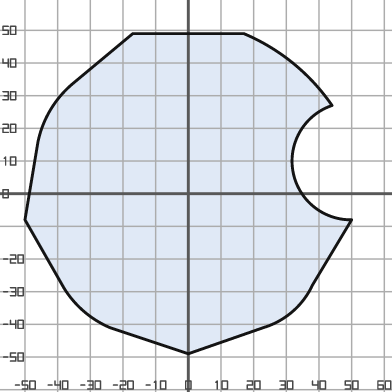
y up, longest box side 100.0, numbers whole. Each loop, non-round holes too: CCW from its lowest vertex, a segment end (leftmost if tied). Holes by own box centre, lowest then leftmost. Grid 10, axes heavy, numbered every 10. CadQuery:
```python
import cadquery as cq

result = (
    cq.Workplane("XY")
    .moveTo(0.0, -49.0)
    .lineTo(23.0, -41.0)
    .threePointArc((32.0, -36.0), (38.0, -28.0))
    .lineTo(50.0, -8.0)
    .threePointArc((32.0, 7.0), (44.0, 27.0))
    .threePointArc((32.0, 40.0), (17.0, 49.0))
    .lineTo(-17.0, 49.0)
    .lineTo(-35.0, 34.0)
    .threePointArc((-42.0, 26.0), (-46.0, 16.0))
    .lineTo(-50.0, -8.0)
    .lineTo(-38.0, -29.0)
    .threePointArc((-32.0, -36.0), (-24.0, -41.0))
    .close()
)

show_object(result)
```